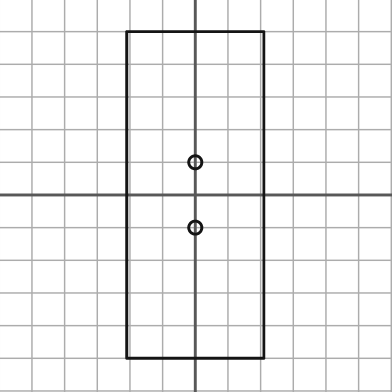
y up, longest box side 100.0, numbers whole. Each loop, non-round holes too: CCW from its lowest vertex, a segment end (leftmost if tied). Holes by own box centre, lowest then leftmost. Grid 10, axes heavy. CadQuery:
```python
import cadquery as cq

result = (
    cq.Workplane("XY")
    .moveTo(-21.0, -50.0)
    .lineTo(21.0, -50.0)
    .lineTo(21.0, 50.0)
    .lineTo(-21.0, 50.0)
    .close()
    .moveTo(0.0, -10.0)
    .circle(2.0)
    .moveTo(0.0, 10.0)
    .circle(2.0)
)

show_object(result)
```